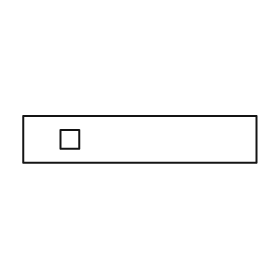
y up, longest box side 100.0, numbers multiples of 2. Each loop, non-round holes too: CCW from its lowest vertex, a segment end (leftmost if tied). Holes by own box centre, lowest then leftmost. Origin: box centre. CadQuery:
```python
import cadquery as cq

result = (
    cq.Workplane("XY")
    .moveTo(-50.0, -10.0)
    .lineTo(50.0, -10.0)
    .lineTo(50.0, 10.0)
    .lineTo(-50.0, 10.0)
    .close()
    .moveTo(-34.0, -4.0)
    .lineTo(-26.0, -4.0)
    .lineTo(-26.0, 4.0)
    .lineTo(-34.0, 4.0)
    .close()
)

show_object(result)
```